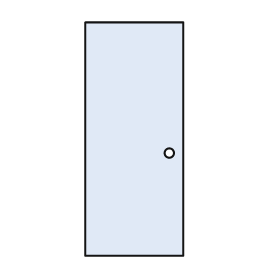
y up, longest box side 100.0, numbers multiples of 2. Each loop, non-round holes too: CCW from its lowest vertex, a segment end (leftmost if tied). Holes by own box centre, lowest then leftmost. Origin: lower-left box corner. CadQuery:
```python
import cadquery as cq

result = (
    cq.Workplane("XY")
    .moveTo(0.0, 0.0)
    .lineTo(42.0, 0.0)
    .lineTo(42.0, 100.0)
    .lineTo(0.0, 100.0)
    .close()
    .moveTo(36.0, 44.0)
    .circle(2.0)
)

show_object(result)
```